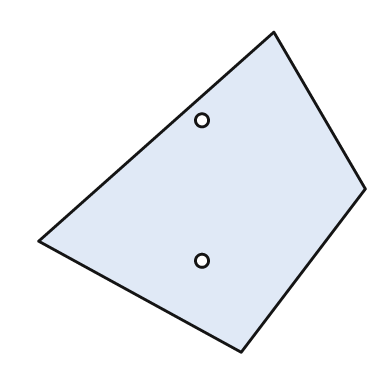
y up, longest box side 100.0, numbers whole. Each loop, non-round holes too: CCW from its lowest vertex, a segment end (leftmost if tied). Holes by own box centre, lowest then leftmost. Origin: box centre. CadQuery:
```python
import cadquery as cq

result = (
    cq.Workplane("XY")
    .moveTo(12.0, -49.0)
    .lineTo(50.0, 1.0)
    .lineTo(22.0, 49.0)
    .lineTo(-50.0, -15.0)
    .close()
    .moveTo(0.0, -21.0)
    .circle(2.0)
    .moveTo(0.0, 22.0)
    .circle(2.0)
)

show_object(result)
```